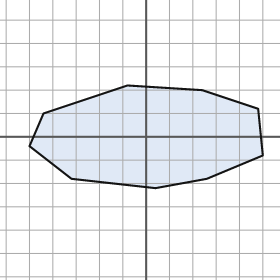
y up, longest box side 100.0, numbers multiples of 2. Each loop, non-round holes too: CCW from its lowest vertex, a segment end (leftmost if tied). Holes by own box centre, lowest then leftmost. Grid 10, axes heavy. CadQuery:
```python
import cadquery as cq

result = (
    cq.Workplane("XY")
    .moveTo(4.0, -22.0)
    .lineTo(26.0, -18.0)
    .lineTo(50.0, -8.0)
    .lineTo(48.0, 12.0)
    .lineTo(24.0, 20.0)
    .lineTo(-8.0, 22.0)
    .lineTo(-44.0, 10.0)
    .lineTo(-50.0, -4.0)
    .lineTo(-32.0, -18.0)
    .close()
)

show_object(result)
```